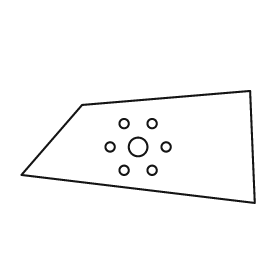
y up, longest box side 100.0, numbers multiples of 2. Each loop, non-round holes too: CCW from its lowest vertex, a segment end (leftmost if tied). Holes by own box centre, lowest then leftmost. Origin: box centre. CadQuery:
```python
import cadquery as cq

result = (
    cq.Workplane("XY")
    .moveTo(50.0, -24.0)
    .lineTo(48.0, 24.0)
    .lineTo(-24.0, 18.0)
    .lineTo(-50.0, -12.0)
    .close()
    .moveTo(-6.0, -10.0)
    .circle(2.0)
    .moveTo(6.0, -10.0)
    .circle(2.0)
    .moveTo(-12.0, 0.0)
    .circle(2.0)
    .moveTo(0.0, 0.0)
    .circle(4.0)
    .moveTo(12.0, 0.0)
    .circle(2.0)
    .moveTo(-6.0, 10.0)
    .circle(2.0)
    .moveTo(6.0, 10.0)
    .circle(2.0)
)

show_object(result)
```